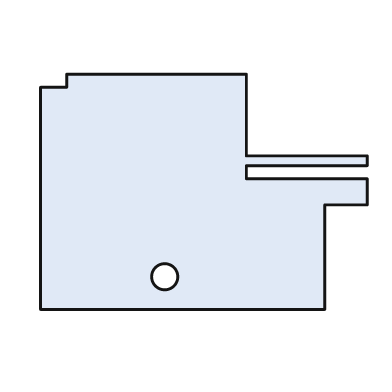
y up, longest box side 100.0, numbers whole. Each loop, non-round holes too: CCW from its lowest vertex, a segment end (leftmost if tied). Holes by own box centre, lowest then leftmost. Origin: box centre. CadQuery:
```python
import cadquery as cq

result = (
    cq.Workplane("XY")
    .moveTo(-50.0, -36.0)
    .lineTo(37.0, -36.0)
    .lineTo(37.0, -4.0)
    .lineTo(50.0, -4.0)
    .lineTo(50.0, 4.0)
    .lineTo(13.0, 4.0)
    .lineTo(13.0, 8.0)
    .lineTo(50.0, 8.0)
    .lineTo(50.0, 11.0)
    .lineTo(13.0, 11.0)
    .lineTo(13.0, 36.0)
    .lineTo(-42.0, 36.0)
    .lineTo(-42.0, 32.0)
    .lineTo(-50.0, 32.0)
    .close()
    .moveTo(-12.0, -26.0)
    .circle(4.0)
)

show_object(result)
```